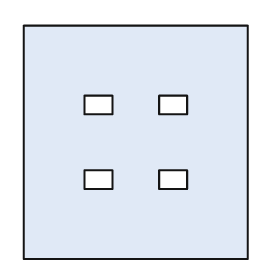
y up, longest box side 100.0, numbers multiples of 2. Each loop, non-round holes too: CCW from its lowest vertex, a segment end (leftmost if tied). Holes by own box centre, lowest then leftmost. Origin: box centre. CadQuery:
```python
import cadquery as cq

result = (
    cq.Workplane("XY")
    .moveTo(-48.0, -50.0)
    .lineTo(48.0, -50.0)
    .lineTo(48.0, 50.0)
    .lineTo(-48.0, 50.0)
    .close()
    .moveTo(-22.0, -20.0)
    .lineTo(-10.0, -20.0)
    .lineTo(-10.0, -12.0)
    .lineTo(-22.0, -12.0)
    .close()
    .moveTo(10.0, -20.0)
    .lineTo(22.0, -20.0)
    .lineTo(22.0, -12.0)
    .lineTo(10.0, -12.0)
    .close()
    .moveTo(-22.0, 12.0)
    .lineTo(-10.0, 12.0)
    .lineTo(-10.0, 20.0)
    .lineTo(-22.0, 20.0)
    .close()
    .moveTo(10.0, 12.0)
    .lineTo(22.0, 12.0)
    .lineTo(22.0, 20.0)
    .lineTo(10.0, 20.0)
    .close()
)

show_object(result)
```